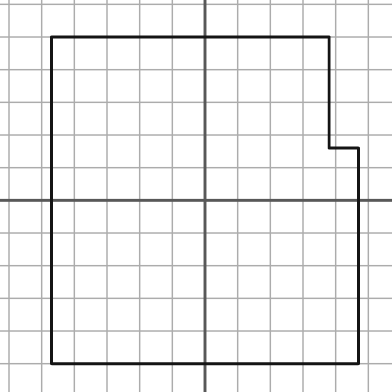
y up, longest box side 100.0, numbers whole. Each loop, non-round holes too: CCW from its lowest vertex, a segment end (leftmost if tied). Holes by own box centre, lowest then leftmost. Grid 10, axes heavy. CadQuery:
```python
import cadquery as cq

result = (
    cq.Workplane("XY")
    .moveTo(-47.0, -50.0)
    .lineTo(47.0, -50.0)
    .lineTo(47.0, 16.0)
    .lineTo(38.0, 16.0)
    .lineTo(38.0, 50.0)
    .lineTo(-47.0, 50.0)
    .close()
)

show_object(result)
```